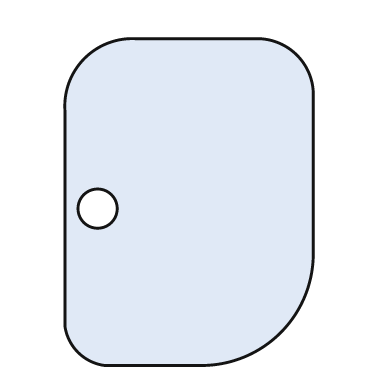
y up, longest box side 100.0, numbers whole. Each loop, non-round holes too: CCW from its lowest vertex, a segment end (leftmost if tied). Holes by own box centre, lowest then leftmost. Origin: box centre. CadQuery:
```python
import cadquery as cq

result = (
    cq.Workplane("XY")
    .moveTo(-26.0, -50.0)
    .lineTo(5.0, -50.0)
    .threePointArc((28.0, -40.0), (38.0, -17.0))
    .lineTo(38.0, 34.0)
    .threePointArc((33.0, 45.0), (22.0, 50.0))
    .lineTo(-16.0, 50.0)
    .threePointArc((-32.0, 44.0), (-38.0, 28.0))
    .lineTo(-38.0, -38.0)
    .threePointArc((-34.0, -46.0), (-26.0, -50.0))
    .close()
    .moveTo(-28.0, -2.0)
    .circle(6.0)
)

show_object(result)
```